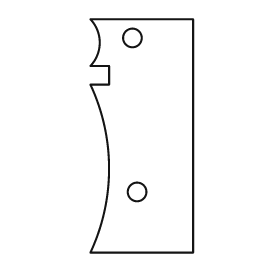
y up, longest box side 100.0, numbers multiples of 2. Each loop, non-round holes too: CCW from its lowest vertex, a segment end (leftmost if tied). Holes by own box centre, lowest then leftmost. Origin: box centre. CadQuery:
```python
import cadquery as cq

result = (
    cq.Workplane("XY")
    .moveTo(-22.0, -50.0)
    .lineTo(22.0, -50.0)
    .lineTo(22.0, 50.0)
    .lineTo(-22.0, 50.0)
    .threePointArc((-18.0, 40.0), (-22.0, 30.0))
    .lineTo(-14.0, 30.0)
    .lineTo(-14.0, 22.0)
    .lineTo(-22.0, 22.0)
    .threePointArc((-14.0, -14.0), (-22.0, -50.0))
    .close()
    .moveTo(-2.0, -24.0)
    .circle(4.0)
    .moveTo(-4.0, 42.0)
    .circle(4.0)
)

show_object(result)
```